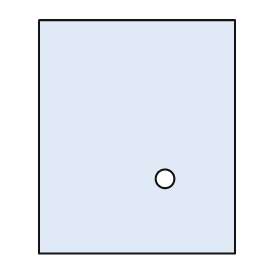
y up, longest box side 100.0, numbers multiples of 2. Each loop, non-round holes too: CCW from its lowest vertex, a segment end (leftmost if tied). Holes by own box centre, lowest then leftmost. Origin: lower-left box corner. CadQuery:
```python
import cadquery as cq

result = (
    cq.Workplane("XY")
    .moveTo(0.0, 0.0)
    .lineTo(84.0, 0.0)
    .lineTo(84.0, 100.0)
    .lineTo(0.0, 100.0)
    .close()
    .moveTo(54.0, 32.0)
    .circle(4.0)
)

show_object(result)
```